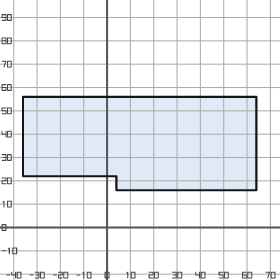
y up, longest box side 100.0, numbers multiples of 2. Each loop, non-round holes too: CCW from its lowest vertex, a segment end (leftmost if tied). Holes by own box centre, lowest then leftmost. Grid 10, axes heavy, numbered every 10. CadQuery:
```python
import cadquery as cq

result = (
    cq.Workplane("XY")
    .moveTo(4.0, 16.0)
    .lineTo(64.0, 16.0)
    .lineTo(64.0, 56.0)
    .lineTo(-36.0, 56.0)
    .lineTo(-36.0, 22.0)
    .lineTo(4.0, 22.0)
    .close()
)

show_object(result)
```